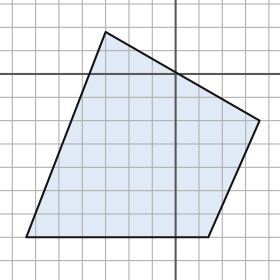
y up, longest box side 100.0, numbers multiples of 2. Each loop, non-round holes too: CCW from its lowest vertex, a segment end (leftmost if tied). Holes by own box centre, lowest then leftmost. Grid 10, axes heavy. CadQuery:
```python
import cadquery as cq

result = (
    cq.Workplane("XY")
    .moveTo(-64.0, -70.0)
    .lineTo(14.0, -70.0)
    .lineTo(36.0, -20.0)
    .lineTo(-30.0, 18.0)
    .close()
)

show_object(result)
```